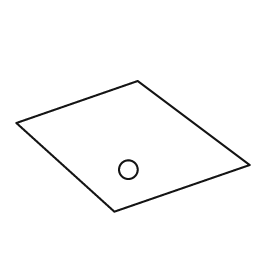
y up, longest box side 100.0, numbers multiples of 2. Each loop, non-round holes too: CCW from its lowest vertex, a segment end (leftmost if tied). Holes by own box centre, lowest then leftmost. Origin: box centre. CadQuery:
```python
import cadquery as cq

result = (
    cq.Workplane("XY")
    .moveTo(-8.0, -28.0)
    .lineTo(50.0, -8.0)
    .lineTo(2.0, 28.0)
    .lineTo(-50.0, 10.0)
    .close()
    .moveTo(-2.0, -10.0)
    .circle(4.0)
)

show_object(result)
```